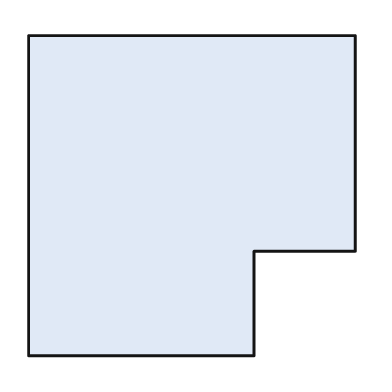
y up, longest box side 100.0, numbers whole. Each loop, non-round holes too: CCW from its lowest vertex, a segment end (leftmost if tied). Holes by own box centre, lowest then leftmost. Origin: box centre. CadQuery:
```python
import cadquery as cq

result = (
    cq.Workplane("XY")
    .moveTo(-50.0, -49.0)
    .lineTo(19.0, -49.0)
    .lineTo(19.0, -17.0)
    .lineTo(50.0, -17.0)
    .lineTo(50.0, 49.0)
    .lineTo(-50.0, 49.0)
    .close()
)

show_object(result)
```